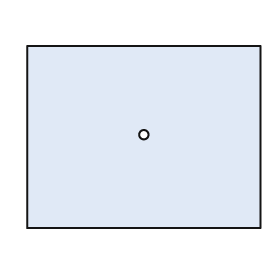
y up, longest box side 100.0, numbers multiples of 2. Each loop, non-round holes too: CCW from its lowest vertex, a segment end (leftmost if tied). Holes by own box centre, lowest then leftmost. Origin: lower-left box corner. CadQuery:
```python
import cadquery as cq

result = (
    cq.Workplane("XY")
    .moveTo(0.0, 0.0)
    .lineTo(100.0, 0.0)
    .lineTo(100.0, 78.0)
    .lineTo(0.0, 78.0)
    .close()
    .moveTo(50.0, 40.0)
    .circle(2.0)
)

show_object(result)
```